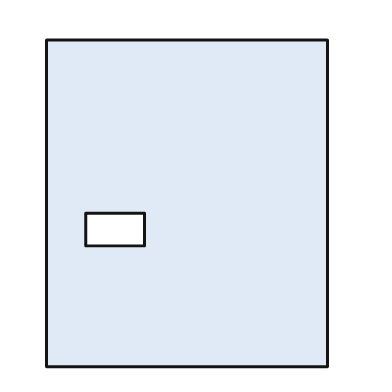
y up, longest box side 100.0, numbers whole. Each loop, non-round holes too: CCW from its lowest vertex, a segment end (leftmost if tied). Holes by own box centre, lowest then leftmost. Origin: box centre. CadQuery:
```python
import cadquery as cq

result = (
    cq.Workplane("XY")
    .moveTo(-43.0, -50.0)
    .lineTo(43.0, -50.0)
    .lineTo(43.0, 50.0)
    .lineTo(-43.0, 50.0)
    .close()
    .moveTo(-31.0, -13.0)
    .lineTo(-13.0, -13.0)
    .lineTo(-13.0, -3.0)
    .lineTo(-31.0, -3.0)
    .close()
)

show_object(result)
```